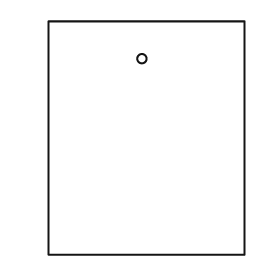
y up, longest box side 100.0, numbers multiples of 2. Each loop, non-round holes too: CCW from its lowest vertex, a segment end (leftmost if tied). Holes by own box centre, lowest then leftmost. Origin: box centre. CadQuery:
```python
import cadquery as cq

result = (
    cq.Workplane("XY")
    .moveTo(-42.0, -50.0)
    .lineTo(42.0, -50.0)
    .lineTo(42.0, 50.0)
    .lineTo(-42.0, 50.0)
    .close()
    .moveTo(-2.0, 34.0)
    .circle(2.0)
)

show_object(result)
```